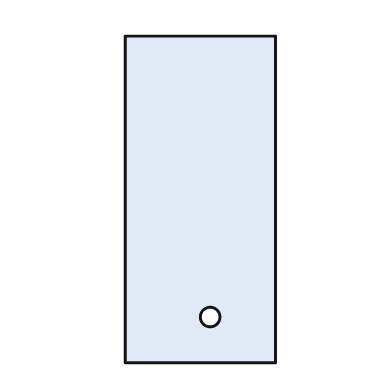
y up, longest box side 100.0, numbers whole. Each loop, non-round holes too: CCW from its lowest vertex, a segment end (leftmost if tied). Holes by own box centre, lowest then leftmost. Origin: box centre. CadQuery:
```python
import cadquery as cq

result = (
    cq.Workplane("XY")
    .moveTo(-23.0, -50.0)
    .lineTo(23.0, -50.0)
    .lineTo(23.0, 50.0)
    .lineTo(-23.0, 50.0)
    .close()
    .moveTo(3.0, -36.0)
    .circle(3.0)
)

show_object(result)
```